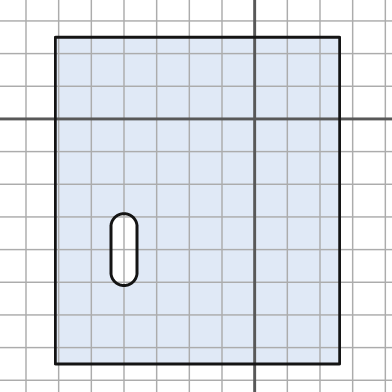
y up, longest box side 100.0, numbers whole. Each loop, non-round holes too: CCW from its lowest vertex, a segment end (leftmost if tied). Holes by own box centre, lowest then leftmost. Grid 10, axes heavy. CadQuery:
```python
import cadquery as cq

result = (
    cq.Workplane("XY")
    .moveTo(-61.0, -75.0)
    .lineTo(26.0, -75.0)
    .lineTo(26.0, 25.0)
    .lineTo(-61.0, 25.0)
    .close()
    .moveTo(-44.0, -47.0)
    .threePointArc((-40.0, -51.0), (-36.0, -47.0))
    .lineTo(-36.0, -33.0)
    .threePointArc((-40.0, -29.0), (-44.0, -33.0))
    .close()
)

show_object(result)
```